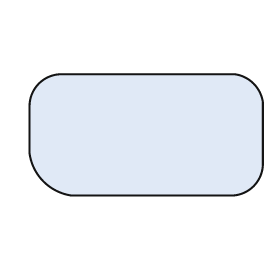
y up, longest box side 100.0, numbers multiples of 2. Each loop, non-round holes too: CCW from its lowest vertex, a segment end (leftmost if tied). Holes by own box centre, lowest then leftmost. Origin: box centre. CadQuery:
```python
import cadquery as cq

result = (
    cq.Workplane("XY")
    .moveTo(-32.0, -26.0)
    .lineTo(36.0, -26.0)
    .threePointArc((46.0, -22.0), (50.0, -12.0))
    .lineTo(50.0, 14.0)
    .threePointArc((46.0, 22.0), (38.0, 26.0))
    .lineTo(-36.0, 26.0)
    .threePointArc((-46.0, 22.0), (-50.0, 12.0))
    .lineTo(-50.0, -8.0)
    .threePointArc((-44.0, -20.0), (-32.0, -26.0))
    .close()
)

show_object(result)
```